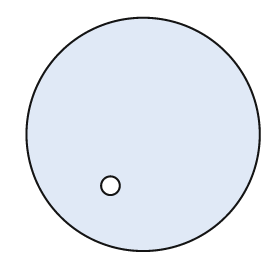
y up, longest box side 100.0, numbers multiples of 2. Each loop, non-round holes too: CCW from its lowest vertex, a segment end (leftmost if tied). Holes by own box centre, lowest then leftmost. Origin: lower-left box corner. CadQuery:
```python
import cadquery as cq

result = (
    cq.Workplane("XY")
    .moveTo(50.0, 50.0)
    .circle(50.0)
    .moveTo(36.0, 28.0)
    .circle(4.0)
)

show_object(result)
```